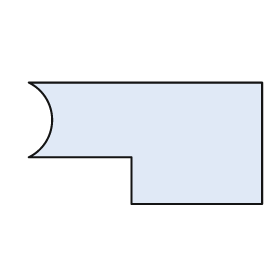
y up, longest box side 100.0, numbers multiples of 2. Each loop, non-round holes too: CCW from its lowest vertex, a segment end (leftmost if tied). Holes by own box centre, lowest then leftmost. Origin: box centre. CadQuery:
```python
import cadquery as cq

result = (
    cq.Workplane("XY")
    .moveTo(-6.0, -26.0)
    .lineTo(50.0, -26.0)
    .lineTo(50.0, 26.0)
    .lineTo(-50.0, 26.0)
    .threePointArc((-40.0, 10.0), (-50.0, -6.0))
    .lineTo(-6.0, -6.0)
    .close()
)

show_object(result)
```